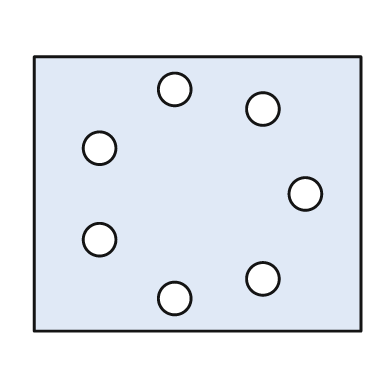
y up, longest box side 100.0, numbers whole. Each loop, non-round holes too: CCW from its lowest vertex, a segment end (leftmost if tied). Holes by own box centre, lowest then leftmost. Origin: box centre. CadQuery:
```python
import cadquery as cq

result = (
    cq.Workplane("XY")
    .moveTo(-50.0, -42.0)
    .lineTo(50.0, -42.0)
    .lineTo(50.0, 42.0)
    .lineTo(-50.0, 42.0)
    .close()
    .moveTo(-7.0, -32.0)
    .circle(5.0)
    .moveTo(20.0, -26.0)
    .circle(5.0)
    .moveTo(-30.0, -14.0)
    .circle(5.0)
    .moveTo(33.0, 0.0)
    .circle(5.0)
    .moveTo(-30.0, 14.0)
    .circle(5.0)
    .moveTo(20.0, 26.0)
    .circle(5.0)
    .moveTo(-7.0, 32.0)
    .circle(5.0)
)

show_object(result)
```